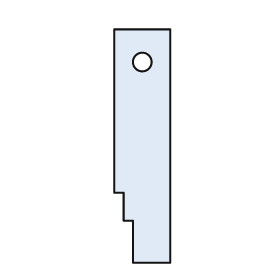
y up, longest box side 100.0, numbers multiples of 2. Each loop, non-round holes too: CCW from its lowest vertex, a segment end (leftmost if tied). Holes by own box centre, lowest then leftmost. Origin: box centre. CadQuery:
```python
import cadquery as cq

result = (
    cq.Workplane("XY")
    .moveTo(-4.0, -50.0)
    .lineTo(12.0, -50.0)
    .lineTo(12.0, 50.0)
    .lineTo(-12.0, 50.0)
    .lineTo(-12.0, -20.0)
    .lineTo(-8.0, -20.0)
    .lineTo(-8.0, -32.0)
    .lineTo(-4.0, -32.0)
    .close()
    .moveTo(0.0, 36.0)
    .circle(4.0)
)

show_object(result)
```